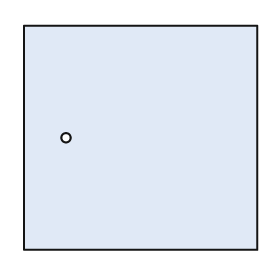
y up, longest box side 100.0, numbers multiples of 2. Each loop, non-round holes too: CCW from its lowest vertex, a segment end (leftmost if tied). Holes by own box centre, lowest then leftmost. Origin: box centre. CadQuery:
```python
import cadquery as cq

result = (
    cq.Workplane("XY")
    .moveTo(-50.0, -48.0)
    .lineTo(50.0, -48.0)
    .lineTo(50.0, 48.0)
    .lineTo(-50.0, 48.0)
    .close()
    .moveTo(-32.0, 0.0)
    .circle(2.0)
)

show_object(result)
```